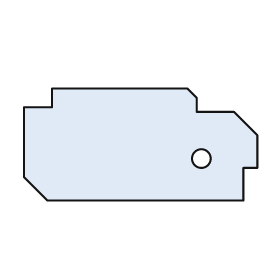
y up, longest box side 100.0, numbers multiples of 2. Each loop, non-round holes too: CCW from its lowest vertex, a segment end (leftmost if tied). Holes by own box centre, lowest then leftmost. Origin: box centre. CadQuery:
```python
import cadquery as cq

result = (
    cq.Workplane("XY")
    .moveTo(-40.0, -24.0)
    .lineTo(44.0, -24.0)
    .lineTo(44.0, -10.0)
    .lineTo(50.0, -10.0)
    .lineTo(50.0, 4.0)
    .lineTo(40.0, 14.0)
    .lineTo(24.0, 14.0)
    .lineTo(24.0, 20.0)
    .lineTo(20.0, 24.0)
    .lineTo(-38.0, 24.0)
    .lineTo(-38.0, 16.0)
    .lineTo(-50.0, 16.0)
    .lineTo(-50.0, -14.0)
    .close()
    .moveTo(26.0, -6.0)
    .circle(4.0)
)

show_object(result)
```